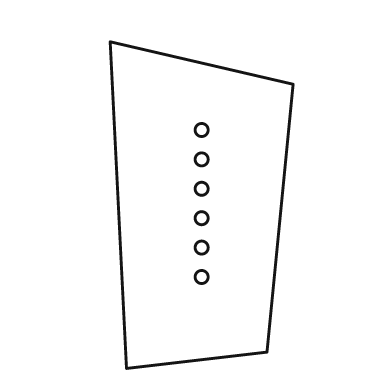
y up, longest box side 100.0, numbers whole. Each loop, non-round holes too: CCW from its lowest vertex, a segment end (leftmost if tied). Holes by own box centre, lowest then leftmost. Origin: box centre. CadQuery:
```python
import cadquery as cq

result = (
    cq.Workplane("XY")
    .moveTo(-23.0, -50.0)
    .lineTo(20.0, -45.0)
    .lineTo(28.0, 37.0)
    .lineTo(-28.0, 50.0)
    .close()
    .moveTo(0.0, -22.0)
    .circle(2.0)
    .moveTo(0.0, -13.0)
    .circle(2.0)
    .moveTo(0.0, -4.0)
    .circle(2.0)
    .moveTo(0.0, 5.0)
    .circle(2.0)
    .moveTo(0.0, 14.0)
    .circle(2.0)
    .moveTo(0.0, 23.0)
    .circle(2.0)
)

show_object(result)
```